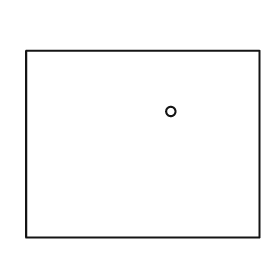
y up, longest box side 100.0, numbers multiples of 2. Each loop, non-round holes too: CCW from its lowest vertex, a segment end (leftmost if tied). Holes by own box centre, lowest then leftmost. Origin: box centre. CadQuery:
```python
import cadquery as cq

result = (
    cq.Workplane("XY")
    .moveTo(-50.0, -40.0)
    .lineTo(50.0, -40.0)
    .lineTo(50.0, 40.0)
    .lineTo(-50.0, 40.0)
    .close()
    .moveTo(12.0, 14.0)
    .circle(2.0)
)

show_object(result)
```